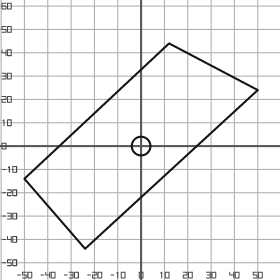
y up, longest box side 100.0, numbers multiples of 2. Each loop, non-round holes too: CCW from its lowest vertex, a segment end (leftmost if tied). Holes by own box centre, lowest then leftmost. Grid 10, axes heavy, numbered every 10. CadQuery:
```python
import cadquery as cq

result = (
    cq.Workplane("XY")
    .moveTo(-24.0, -44.0)
    .lineTo(50.0, 24.0)
    .lineTo(12.0, 44.0)
    .lineTo(-50.0, -14.0)
    .close()
    .moveTo(0.0, 0.0)
    .circle(4.0)
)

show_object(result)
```